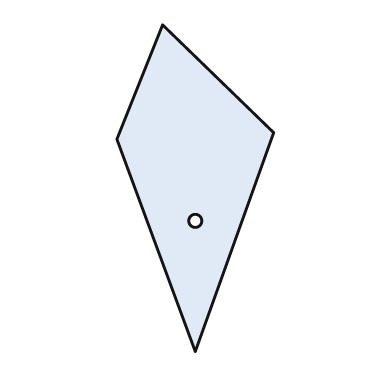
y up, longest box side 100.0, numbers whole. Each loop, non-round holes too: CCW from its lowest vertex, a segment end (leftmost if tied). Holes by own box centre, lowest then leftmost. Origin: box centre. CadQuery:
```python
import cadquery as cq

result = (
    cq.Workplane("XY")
    .moveTo(0.0, -50.0)
    .lineTo(24.0, 17.0)
    .lineTo(-10.0, 50.0)
    .lineTo(-24.0, 15.0)
    .close()
    .moveTo(0.0, -10.0)
    .circle(2.0)
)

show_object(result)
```